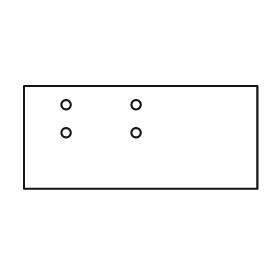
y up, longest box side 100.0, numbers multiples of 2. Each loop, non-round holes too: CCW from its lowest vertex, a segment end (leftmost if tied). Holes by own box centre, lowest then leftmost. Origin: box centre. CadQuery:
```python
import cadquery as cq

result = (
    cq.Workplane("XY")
    .moveTo(-50.0, -22.0)
    .lineTo(50.0, -22.0)
    .lineTo(50.0, 22.0)
    .lineTo(-50.0, 22.0)
    .close()
    .moveTo(-32.0, 2.0)
    .circle(2.0)
    .moveTo(-2.0, 2.0)
    .circle(2.0)
    .moveTo(-32.0, 14.0)
    .circle(2.0)
    .moveTo(-2.0, 14.0)
    .circle(2.0)
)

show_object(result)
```